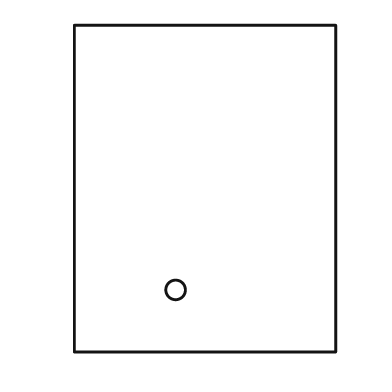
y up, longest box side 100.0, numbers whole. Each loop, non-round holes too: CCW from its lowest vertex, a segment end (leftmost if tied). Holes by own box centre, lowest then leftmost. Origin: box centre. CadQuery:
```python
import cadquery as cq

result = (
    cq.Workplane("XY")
    .moveTo(-40.0, -50.0)
    .lineTo(40.0, -50.0)
    .lineTo(40.0, 50.0)
    .lineTo(-40.0, 50.0)
    .close()
    .moveTo(-9.0, -31.0)
    .circle(3.0)
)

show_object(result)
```